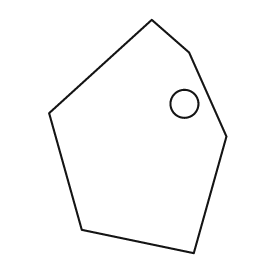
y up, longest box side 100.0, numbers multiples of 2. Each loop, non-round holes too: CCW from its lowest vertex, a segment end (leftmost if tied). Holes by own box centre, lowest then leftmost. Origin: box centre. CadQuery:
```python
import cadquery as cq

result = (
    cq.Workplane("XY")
    .moveTo(24.0, -50.0)
    .lineTo(38.0, 0.0)
    .lineTo(22.0, 36.0)
    .lineTo(6.0, 50.0)
    .lineTo(-38.0, 10.0)
    .lineTo(-24.0, -40.0)
    .close()
    .moveTo(20.0, 14.0)
    .circle(6.0)
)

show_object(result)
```